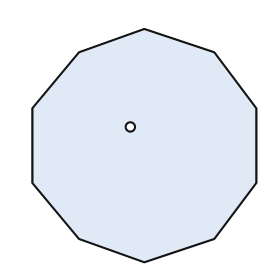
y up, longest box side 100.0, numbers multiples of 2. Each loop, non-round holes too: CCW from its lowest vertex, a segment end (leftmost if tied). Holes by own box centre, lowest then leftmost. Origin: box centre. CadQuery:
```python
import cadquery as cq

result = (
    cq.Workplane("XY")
    .moveTo(0.0, -50.0)
    .lineTo(30.0, -40.0)
    .lineTo(48.0, -16.0)
    .lineTo(48.0, 16.0)
    .lineTo(30.0, 40.0)
    .lineTo(0.0, 50.0)
    .lineTo(-28.0, 40.0)
    .lineTo(-48.0, 16.0)
    .lineTo(-48.0, -16.0)
    .lineTo(-28.0, -40.0)
    .close()
    .moveTo(-6.0, 8.0)
    .circle(2.0)
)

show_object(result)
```